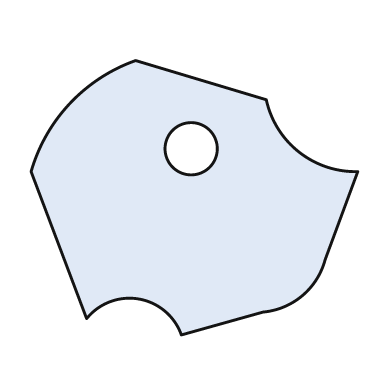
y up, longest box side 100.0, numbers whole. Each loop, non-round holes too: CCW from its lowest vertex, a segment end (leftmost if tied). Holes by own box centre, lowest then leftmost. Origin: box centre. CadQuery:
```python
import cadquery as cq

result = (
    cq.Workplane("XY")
    .moveTo(-4.0, -42.0)
    .lineTo(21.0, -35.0)
    .threePointArc((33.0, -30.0), (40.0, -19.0))
    .lineTo(50.0, 8.0)
    .threePointArc((32.0, 14.0), (22.0, 30.0))
    .lineTo(-18.0, 42.0)
    .threePointArc((-38.0, 29.0), (-50.0, 8.0))
    .lineTo(-33.0, -37.0)
    .threePointArc((-17.0, -31.0), (-4.0, -42.0))
    .close()
    .moveTo(-1.0, 15.0)
    .circle(8.0)
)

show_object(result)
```